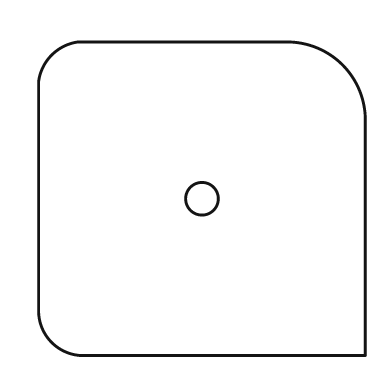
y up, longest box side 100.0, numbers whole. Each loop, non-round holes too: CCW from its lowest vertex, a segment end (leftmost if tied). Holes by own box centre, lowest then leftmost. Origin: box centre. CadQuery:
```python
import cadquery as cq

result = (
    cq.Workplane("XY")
    .moveTo(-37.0, -48.0)
    .lineTo(50.0, -48.0)
    .lineTo(50.0, 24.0)
    .threePointArc((43.0, 41.0), (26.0, 48.0))
    .lineTo(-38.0, 48.0)
    .threePointArc((-46.0, 44.0), (-50.0, 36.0))
    .lineTo(-50.0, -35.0)
    .threePointArc((-46.0, -44.0), (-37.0, -48.0))
    .close()
    .moveTo(0.0, 0.0)
    .circle(5.0)
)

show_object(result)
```